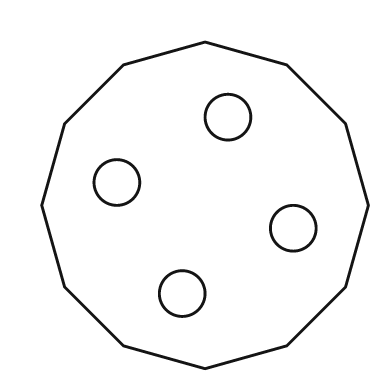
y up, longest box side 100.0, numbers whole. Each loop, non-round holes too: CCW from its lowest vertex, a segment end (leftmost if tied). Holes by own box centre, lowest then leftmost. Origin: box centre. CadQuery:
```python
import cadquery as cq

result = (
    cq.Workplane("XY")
    .moveTo(0.0, -50.0)
    .lineTo(25.0, -43.0)
    .lineTo(43.0, -25.0)
    .lineTo(50.0, 0.0)
    .lineTo(43.0, 25.0)
    .lineTo(25.0, 43.0)
    .lineTo(0.0, 50.0)
    .lineTo(-25.0, 43.0)
    .lineTo(-43.0, 25.0)
    .lineTo(-50.0, 0.0)
    .lineTo(-43.0, -25.0)
    .lineTo(-25.0, -43.0)
    .close()
    .moveTo(-7.0, -27.0)
    .circle(7.0)
    .moveTo(27.0, -7.0)
    .circle(7.0)
    .moveTo(-27.0, 7.0)
    .circle(7.0)
    .moveTo(7.0, 27.0)
    .circle(7.0)
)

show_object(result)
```